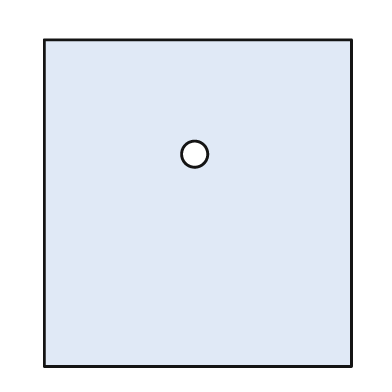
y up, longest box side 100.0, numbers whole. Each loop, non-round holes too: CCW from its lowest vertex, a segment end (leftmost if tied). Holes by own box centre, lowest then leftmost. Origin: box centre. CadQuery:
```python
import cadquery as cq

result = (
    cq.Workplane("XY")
    .moveTo(-47.0, -50.0)
    .lineTo(47.0, -50.0)
    .lineTo(47.0, 50.0)
    .lineTo(-47.0, 50.0)
    .close()
    .moveTo(-1.0, 15.0)
    .circle(4.0)
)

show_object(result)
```